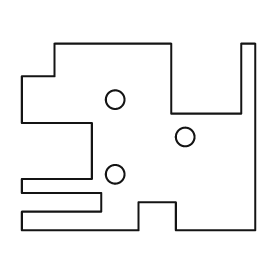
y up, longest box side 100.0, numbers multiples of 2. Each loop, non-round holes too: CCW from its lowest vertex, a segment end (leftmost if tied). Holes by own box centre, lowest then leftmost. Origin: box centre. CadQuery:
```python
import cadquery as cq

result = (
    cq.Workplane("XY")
    .moveTo(-50.0, -40.0)
    .lineTo(0.0, -40.0)
    .lineTo(0.0, -28.0)
    .lineTo(16.0, -28.0)
    .lineTo(16.0, -40.0)
    .lineTo(50.0, -40.0)
    .lineTo(50.0, 40.0)
    .lineTo(44.0, 40.0)
    .lineTo(44.0, 10.0)
    .lineTo(14.0, 10.0)
    .lineTo(14.0, 40.0)
    .lineTo(-36.0, 40.0)
    .lineTo(-36.0, 26.0)
    .lineTo(-50.0, 26.0)
    .lineTo(-50.0, 6.0)
    .lineTo(-20.0, 6.0)
    .lineTo(-20.0, -18.0)
    .lineTo(-50.0, -18.0)
    .lineTo(-50.0, -24.0)
    .lineTo(-16.0, -24.0)
    .lineTo(-16.0, -32.0)
    .lineTo(-50.0, -32.0)
    .close()
    .moveTo(-10.0, -16.0)
    .circle(4.0)
    .moveTo(20.0, 0.0)
    .circle(4.0)
    .moveTo(-10.0, 16.0)
    .circle(4.0)
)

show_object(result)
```